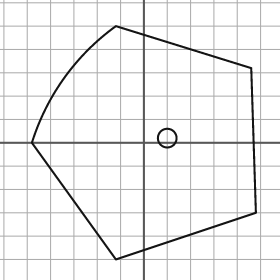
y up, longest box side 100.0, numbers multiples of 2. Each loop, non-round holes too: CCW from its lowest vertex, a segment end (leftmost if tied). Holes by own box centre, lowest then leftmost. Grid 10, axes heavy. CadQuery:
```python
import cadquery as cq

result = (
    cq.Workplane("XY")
    .moveTo(-12.0, -50.0)
    .lineTo(48.0, -30.0)
    .lineTo(46.0, 32.0)
    .lineTo(-12.0, 50.0)
    .threePointArc((-34.0, 28.0), (-48.0, 0.0))
    .close()
    .moveTo(10.0, 2.0)
    .circle(4.0)
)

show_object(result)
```